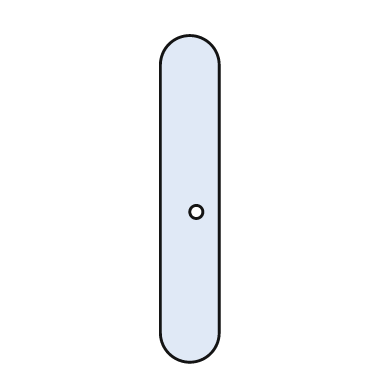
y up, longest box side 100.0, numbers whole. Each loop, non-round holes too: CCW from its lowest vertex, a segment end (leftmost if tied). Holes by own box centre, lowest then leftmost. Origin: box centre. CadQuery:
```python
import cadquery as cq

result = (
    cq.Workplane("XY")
    .moveTo(-9.0, -41.0)
    .threePointArc((0.0, -50.0), (9.0, -41.0))
    .lineTo(9.0, 41.0)
    .threePointArc((0.0, 50.0), (-9.0, 41.0))
    .close()
    .moveTo(2.0, -4.0)
    .circle(2.0)
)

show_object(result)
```